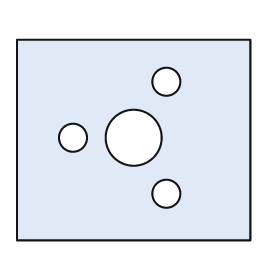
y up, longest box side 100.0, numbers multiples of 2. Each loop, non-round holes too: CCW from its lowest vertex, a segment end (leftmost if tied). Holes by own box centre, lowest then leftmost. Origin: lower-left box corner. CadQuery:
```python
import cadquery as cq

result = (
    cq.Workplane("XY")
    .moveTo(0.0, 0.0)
    .lineTo(100.0, 0.0)
    .lineTo(100.0, 86.0)
    .lineTo(0.0, 86.0)
    .close()
    .moveTo(64.0, 20.0)
    .circle(6.0)
    .moveTo(24.0, 44.0)
    .circle(6.0)
    .moveTo(50.0, 44.0)
    .circle(12.0)
    .moveTo(64.0, 68.0)
    .circle(6.0)
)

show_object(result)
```